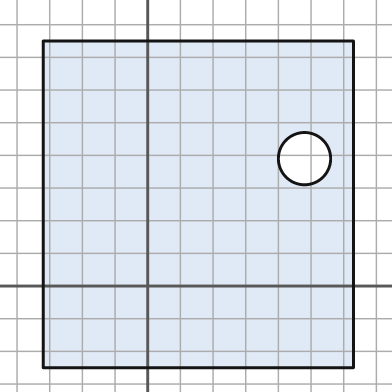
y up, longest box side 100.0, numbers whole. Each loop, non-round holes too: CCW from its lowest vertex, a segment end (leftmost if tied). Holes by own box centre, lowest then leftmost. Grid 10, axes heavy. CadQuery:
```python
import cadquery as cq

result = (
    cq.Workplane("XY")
    .moveTo(-32.0, -25.0)
    .lineTo(63.0, -25.0)
    .lineTo(63.0, 75.0)
    .lineTo(-32.0, 75.0)
    .close()
    .moveTo(48.0, 39.0)
    .circle(8.0)
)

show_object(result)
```